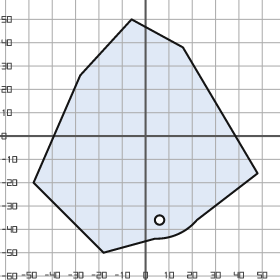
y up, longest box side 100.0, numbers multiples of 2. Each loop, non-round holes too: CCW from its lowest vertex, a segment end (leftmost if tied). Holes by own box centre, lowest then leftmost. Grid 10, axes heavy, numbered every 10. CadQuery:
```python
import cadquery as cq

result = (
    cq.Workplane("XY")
    .moveTo(-18.0, -50.0)
    .lineTo(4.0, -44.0)
    .threePointArc((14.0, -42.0), (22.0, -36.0))
    .lineTo(48.0, -16.0)
    .lineTo(16.0, 38.0)
    .lineTo(-6.0, 50.0)
    .lineTo(-28.0, 26.0)
    .lineTo(-48.0, -20.0)
    .close()
    .moveTo(6.0, -36.0)
    .circle(2.0)
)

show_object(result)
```